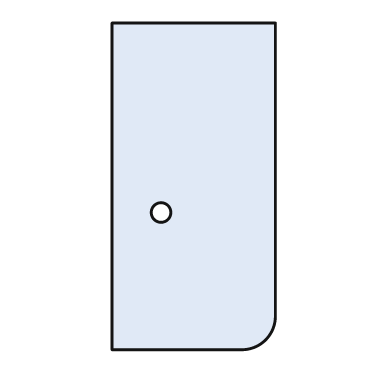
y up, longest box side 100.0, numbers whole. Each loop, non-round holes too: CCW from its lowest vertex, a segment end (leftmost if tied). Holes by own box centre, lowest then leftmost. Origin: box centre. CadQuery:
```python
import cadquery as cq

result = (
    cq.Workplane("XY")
    .moveTo(-25.0, -50.0)
    .lineTo(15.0, -50.0)
    .threePointArc((22.0, -47.0), (25.0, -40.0))
    .lineTo(25.0, 50.0)
    .lineTo(-25.0, 50.0)
    .close()
    .moveTo(-10.0, -8.0)
    .circle(3.0)
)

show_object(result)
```